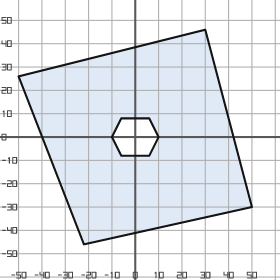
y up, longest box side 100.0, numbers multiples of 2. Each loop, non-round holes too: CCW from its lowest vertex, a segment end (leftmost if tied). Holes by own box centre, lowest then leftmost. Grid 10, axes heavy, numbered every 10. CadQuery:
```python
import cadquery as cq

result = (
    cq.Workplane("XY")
    .moveTo(-22.0, -46.0)
    .lineTo(50.0, -30.0)
    .lineTo(30.0, 46.0)
    .lineTo(-50.0, 26.0)
    .close()
    .moveTo(-6.0, -8.0)
    .lineTo(6.0, -8.0)
    .lineTo(10.0, 0.0)
    .lineTo(6.0, 8.0)
    .lineTo(-6.0, 8.0)
    .lineTo(-10.0, 0.0)
    .close()
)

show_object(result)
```